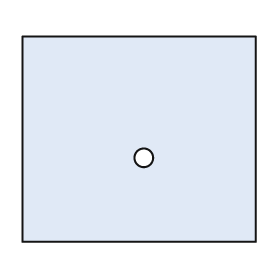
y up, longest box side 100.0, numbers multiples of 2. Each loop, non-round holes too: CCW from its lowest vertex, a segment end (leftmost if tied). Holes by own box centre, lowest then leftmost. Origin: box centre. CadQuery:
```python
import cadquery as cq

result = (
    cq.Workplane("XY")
    .moveTo(-50.0, -44.0)
    .lineTo(50.0, -44.0)
    .lineTo(50.0, 44.0)
    .lineTo(-50.0, 44.0)
    .close()
    .moveTo(2.0, -8.0)
    .circle(4.0)
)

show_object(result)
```